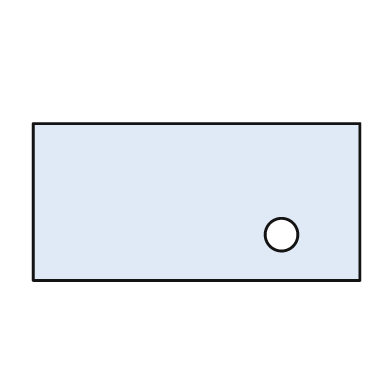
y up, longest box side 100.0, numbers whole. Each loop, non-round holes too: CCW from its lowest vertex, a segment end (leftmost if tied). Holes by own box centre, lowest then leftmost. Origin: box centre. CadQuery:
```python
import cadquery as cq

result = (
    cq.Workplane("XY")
    .moveTo(-50.0, -24.0)
    .lineTo(50.0, -24.0)
    .lineTo(50.0, 24.0)
    .lineTo(-50.0, 24.0)
    .close()
    .moveTo(26.0, -10.0)
    .circle(5.0)
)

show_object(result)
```